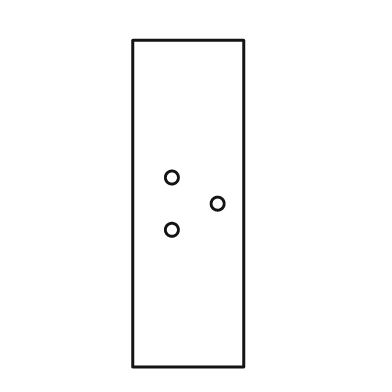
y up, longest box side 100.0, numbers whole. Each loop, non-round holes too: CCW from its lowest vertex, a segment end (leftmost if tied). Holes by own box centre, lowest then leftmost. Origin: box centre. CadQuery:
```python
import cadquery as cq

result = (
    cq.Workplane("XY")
    .moveTo(-17.0, -50.0)
    .lineTo(17.0, -50.0)
    .lineTo(17.0, 50.0)
    .lineTo(-17.0, 50.0)
    .close()
    .moveTo(-5.0, -8.0)
    .circle(2.0)
    .moveTo(9.0, 0.0)
    .circle(2.0)
    .moveTo(-5.0, 8.0)
    .circle(2.0)
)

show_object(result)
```